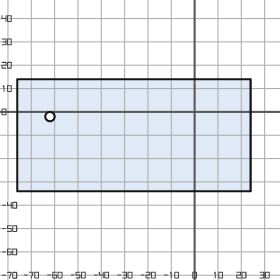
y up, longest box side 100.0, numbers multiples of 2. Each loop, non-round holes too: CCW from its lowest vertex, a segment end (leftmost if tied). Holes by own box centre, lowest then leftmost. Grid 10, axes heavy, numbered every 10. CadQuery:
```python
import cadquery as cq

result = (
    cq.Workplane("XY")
    .moveTo(-76.0, -34.0)
    .lineTo(24.0, -34.0)
    .lineTo(24.0, 14.0)
    .lineTo(-76.0, 14.0)
    .close()
    .moveTo(-62.0, -2.0)
    .circle(2.0)
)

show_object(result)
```